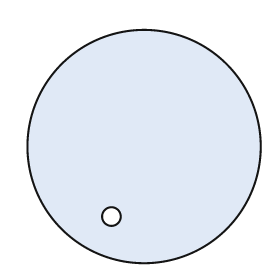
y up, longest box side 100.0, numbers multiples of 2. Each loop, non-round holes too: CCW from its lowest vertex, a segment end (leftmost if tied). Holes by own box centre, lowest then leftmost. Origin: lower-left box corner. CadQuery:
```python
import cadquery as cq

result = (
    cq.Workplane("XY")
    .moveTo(50.0, 50.0)
    .circle(50.0)
    .moveTo(36.0, 20.0)
    .circle(4.0)
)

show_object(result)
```